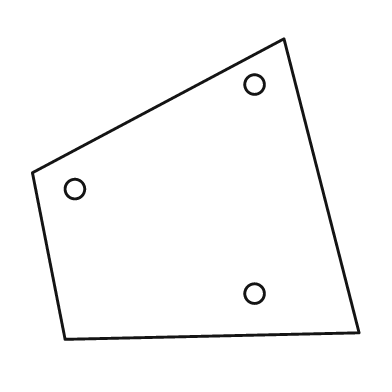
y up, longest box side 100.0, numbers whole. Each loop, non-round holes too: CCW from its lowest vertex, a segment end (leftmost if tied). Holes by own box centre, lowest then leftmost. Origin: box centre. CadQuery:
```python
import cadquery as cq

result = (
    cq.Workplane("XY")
    .moveTo(-40.0, -46.0)
    .lineTo(50.0, -44.0)
    .lineTo(27.0, 46.0)
    .lineTo(-50.0, 5.0)
    .close()
    .moveTo(18.0, -32.0)
    .circle(3.0)
    .moveTo(-37.0, 0.0)
    .circle(3.0)
    .moveTo(18.0, 32.0)
    .circle(3.0)
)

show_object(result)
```